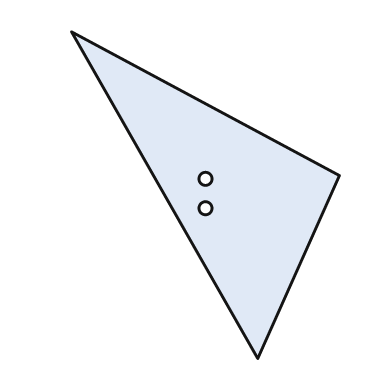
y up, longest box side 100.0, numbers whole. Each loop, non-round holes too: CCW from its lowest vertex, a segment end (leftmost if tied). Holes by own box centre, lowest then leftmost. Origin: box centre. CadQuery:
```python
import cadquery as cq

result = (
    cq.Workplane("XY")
    .moveTo(16.0, -50.0)
    .lineTo(41.0, 6.0)
    .lineTo(-41.0, 50.0)
    .close()
    .moveTo(0.0, -4.0)
    .circle(2.0)
    .moveTo(0.0, 5.0)
    .circle(2.0)
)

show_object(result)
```